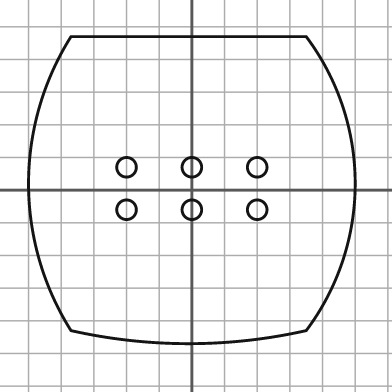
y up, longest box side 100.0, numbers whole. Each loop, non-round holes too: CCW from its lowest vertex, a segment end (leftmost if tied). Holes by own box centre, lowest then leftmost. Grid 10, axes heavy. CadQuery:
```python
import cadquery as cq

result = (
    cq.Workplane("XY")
    .moveTo(-37.0, -43.0)
    .threePointArc((-1.0, -47.0), (35.0, -43.0))
    .threePointArc((50.0, 2.0), (35.0, 47.0))
    .lineTo(-37.0, 47.0)
    .threePointArc((-50.0, 2.0), (-37.0, -43.0))
    .close()
    .moveTo(-20.0, -6.0)
    .circle(3.0)
    .moveTo(0.0, -6.0)
    .circle(3.0)
    .moveTo(20.0, -6.0)
    .circle(3.0)
    .moveTo(-20.0, 7.0)
    .circle(3.0)
    .moveTo(0.0, 7.0)
    .circle(3.0)
    .moveTo(20.0, 7.0)
    .circle(3.0)
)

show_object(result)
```